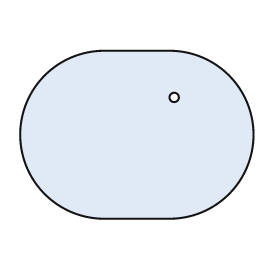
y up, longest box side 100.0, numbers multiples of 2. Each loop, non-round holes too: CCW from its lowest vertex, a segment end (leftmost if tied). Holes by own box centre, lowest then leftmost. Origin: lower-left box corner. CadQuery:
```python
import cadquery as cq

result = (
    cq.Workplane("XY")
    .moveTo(36.0, 0.0)
    .lineTo(64.0, 0.0)
    .threePointArc((100.0, 36.0), (64.0, 72.0))
    .lineTo(36.0, 72.0)
    .threePointArc((0.0, 36.0), (36.0, 0.0))
    .close()
    .moveTo(66.0, 52.0)
    .circle(2.0)
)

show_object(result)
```